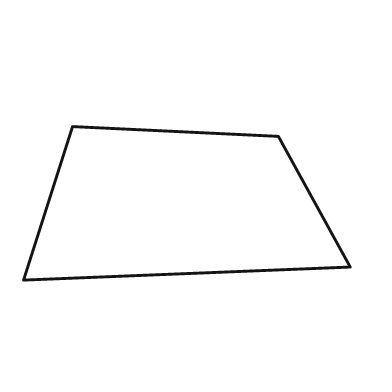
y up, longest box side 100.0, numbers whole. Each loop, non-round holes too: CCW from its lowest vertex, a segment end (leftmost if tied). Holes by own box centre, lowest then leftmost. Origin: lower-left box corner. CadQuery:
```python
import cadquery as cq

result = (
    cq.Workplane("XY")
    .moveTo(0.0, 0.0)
    .lineTo(100.0, 4.0)
    .lineTo(78.0, 44.0)
    .lineTo(15.0, 47.0)
    .close()
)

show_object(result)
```